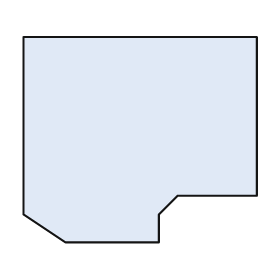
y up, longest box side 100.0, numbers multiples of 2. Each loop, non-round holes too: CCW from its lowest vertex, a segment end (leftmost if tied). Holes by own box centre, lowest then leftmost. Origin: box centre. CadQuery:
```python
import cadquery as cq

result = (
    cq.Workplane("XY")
    .moveTo(-32.0, -44.0)
    .lineTo(8.0, -44.0)
    .lineTo(8.0, -32.0)
    .lineTo(16.0, -24.0)
    .lineTo(50.0, -24.0)
    .lineTo(50.0, 44.0)
    .lineTo(-50.0, 44.0)
    .lineTo(-50.0, -32.0)
    .close()
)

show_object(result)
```